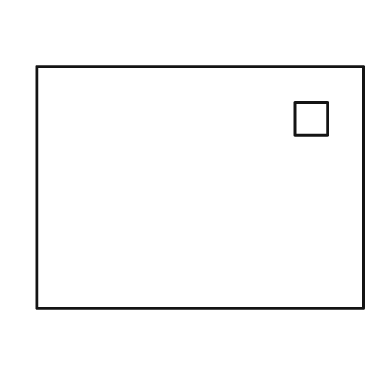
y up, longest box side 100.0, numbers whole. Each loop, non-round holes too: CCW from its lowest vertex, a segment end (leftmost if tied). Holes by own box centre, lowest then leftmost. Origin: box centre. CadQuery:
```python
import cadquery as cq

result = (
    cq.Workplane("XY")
    .moveTo(-50.0, -37.0)
    .lineTo(50.0, -37.0)
    .lineTo(50.0, 37.0)
    .lineTo(-50.0, 37.0)
    .close()
    .moveTo(29.0, 16.0)
    .lineTo(39.0, 16.0)
    .lineTo(39.0, 26.0)
    .lineTo(29.0, 26.0)
    .close()
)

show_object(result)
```